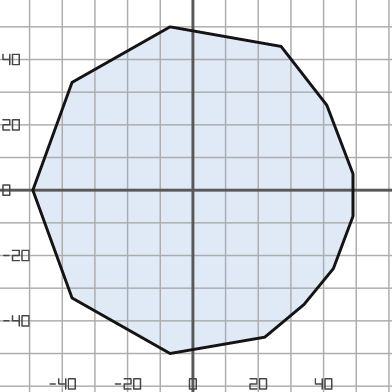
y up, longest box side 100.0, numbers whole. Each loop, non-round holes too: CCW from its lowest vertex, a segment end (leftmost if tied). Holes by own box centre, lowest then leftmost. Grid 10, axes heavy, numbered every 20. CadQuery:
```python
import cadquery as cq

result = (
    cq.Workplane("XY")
    .moveTo(-7.0, -50.0)
    .lineTo(22.0, -45.0)
    .lineTo(34.0, -35.0)
    .lineTo(43.0, -24.0)
    .lineTo(49.0, -8.0)
    .lineTo(49.0, 5.0)
    .lineTo(41.0, 26.0)
    .lineTo(27.0, 44.0)
    .lineTo(-7.0, 50.0)
    .lineTo(-37.0, 33.0)
    .lineTo(-49.0, 0.0)
    .lineTo(-37.0, -33.0)
    .close()
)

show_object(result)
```